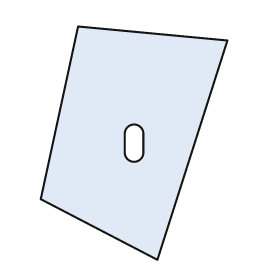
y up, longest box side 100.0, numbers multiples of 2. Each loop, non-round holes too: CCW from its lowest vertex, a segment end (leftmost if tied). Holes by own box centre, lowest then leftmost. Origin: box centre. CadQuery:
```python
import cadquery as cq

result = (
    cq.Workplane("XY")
    .moveTo(10.0, -50.0)
    .lineTo(40.0, 44.0)
    .lineTo(-24.0, 50.0)
    .lineTo(-40.0, -24.0)
    .close()
    .moveTo(-4.0, -4.0)
    .threePointArc((0.0, -8.0), (4.0, -4.0))
    .lineTo(4.0, 4.0)
    .threePointArc((0.0, 8.0), (-4.0, 4.0))
    .close()
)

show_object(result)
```